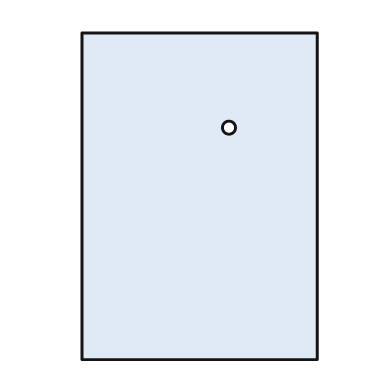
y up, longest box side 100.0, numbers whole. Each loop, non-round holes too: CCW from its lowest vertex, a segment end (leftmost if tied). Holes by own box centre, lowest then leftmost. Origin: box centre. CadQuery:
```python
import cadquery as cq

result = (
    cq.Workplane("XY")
    .moveTo(-36.0, -50.0)
    .lineTo(36.0, -50.0)
    .lineTo(36.0, 50.0)
    .lineTo(-36.0, 50.0)
    .close()
    .moveTo(9.0, 21.0)
    .circle(2.0)
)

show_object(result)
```